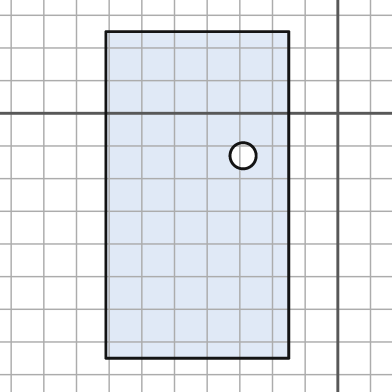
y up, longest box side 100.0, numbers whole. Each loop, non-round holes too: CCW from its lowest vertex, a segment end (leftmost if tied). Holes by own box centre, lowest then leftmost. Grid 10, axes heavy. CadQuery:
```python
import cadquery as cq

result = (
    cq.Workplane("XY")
    .moveTo(-71.0, -75.0)
    .lineTo(-15.0, -75.0)
    .lineTo(-15.0, 25.0)
    .lineTo(-71.0, 25.0)
    .close()
    .moveTo(-29.0, -13.0)
    .circle(4.0)
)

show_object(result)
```